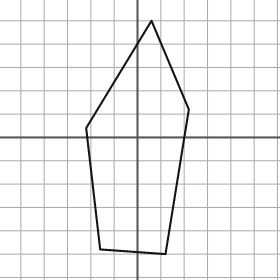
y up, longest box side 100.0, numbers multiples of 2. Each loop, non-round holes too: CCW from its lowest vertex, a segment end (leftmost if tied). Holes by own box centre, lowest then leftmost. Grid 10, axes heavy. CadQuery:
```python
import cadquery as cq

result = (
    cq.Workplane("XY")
    .moveTo(12.0, -50.0)
    .lineTo(22.0, 12.0)
    .lineTo(6.0, 50.0)
    .lineTo(-22.0, 4.0)
    .lineTo(-16.0, -48.0)
    .close()
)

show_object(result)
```